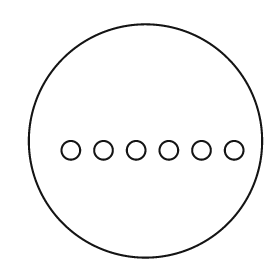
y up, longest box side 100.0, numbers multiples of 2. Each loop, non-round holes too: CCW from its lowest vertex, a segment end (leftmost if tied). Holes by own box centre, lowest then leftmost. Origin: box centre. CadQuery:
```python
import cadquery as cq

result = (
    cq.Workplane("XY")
    .moveTo(0.0, 0.0)
    .circle(50.0)
    .moveTo(-32.0, -4.0)
    .circle(4.0)
    .moveTo(-18.0, -4.0)
    .circle(4.0)
    .moveTo(-4.0, -4.0)
    .circle(4.0)
    .moveTo(10.0, -4.0)
    .circle(4.0)
    .moveTo(24.0, -4.0)
    .circle(4.0)
    .moveTo(38.0, -4.0)
    .circle(4.0)
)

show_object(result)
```